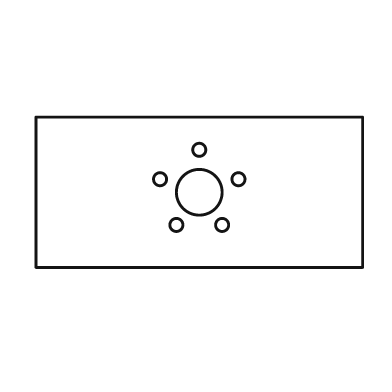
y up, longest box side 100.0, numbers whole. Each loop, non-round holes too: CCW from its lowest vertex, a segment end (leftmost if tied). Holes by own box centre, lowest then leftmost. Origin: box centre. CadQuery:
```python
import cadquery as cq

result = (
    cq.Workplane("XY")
    .moveTo(-50.0, -23.0)
    .lineTo(50.0, -23.0)
    .lineTo(50.0, 23.0)
    .lineTo(-50.0, 23.0)
    .close()
    .moveTo(-7.0, -10.0)
    .circle(2.0)
    .moveTo(7.0, -10.0)
    .circle(2.0)
    .moveTo(0.0, 0.0)
    .circle(7.0)
    .moveTo(-12.0, 4.0)
    .circle(2.0)
    .moveTo(12.0, 4.0)
    .circle(2.0)
    .moveTo(0.0, 13.0)
    .circle(2.0)
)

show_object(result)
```